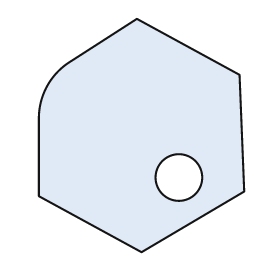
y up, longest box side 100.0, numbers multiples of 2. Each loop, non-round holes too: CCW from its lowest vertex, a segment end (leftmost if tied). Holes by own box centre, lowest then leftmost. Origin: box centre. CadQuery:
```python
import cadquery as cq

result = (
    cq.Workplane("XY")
    .moveTo(0.0, -50.0)
    .lineTo(44.0, -24.0)
    .lineTo(42.0, 26.0)
    .lineTo(-2.0, 50.0)
    .lineTo(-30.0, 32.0)
    .threePointArc((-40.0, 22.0), (-44.0, 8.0))
    .lineTo(-44.0, -26.0)
    .close()
    .moveTo(16.0, -18.0)
    .circle(10.0)
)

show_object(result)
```